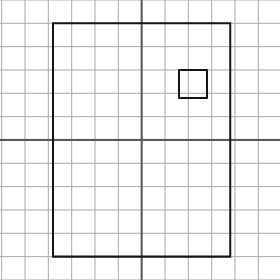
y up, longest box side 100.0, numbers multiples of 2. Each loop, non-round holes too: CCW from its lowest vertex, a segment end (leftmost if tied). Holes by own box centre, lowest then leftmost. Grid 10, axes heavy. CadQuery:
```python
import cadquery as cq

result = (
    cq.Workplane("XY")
    .moveTo(-38.0, -50.0)
    .lineTo(38.0, -50.0)
    .lineTo(38.0, 50.0)
    .lineTo(-38.0, 50.0)
    .close()
    .moveTo(16.0, 18.0)
    .lineTo(28.0, 18.0)
    .lineTo(28.0, 30.0)
    .lineTo(16.0, 30.0)
    .close()
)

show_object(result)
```